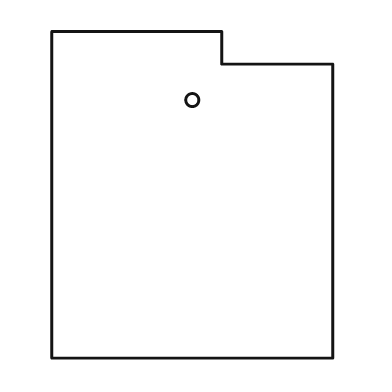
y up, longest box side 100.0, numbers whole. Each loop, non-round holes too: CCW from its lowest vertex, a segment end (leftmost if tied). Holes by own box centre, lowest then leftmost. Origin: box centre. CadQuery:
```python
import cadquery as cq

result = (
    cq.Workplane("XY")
    .moveTo(-43.0, -50.0)
    .lineTo(43.0, -50.0)
    .lineTo(43.0, 40.0)
    .lineTo(9.0, 40.0)
    .lineTo(9.0, 50.0)
    .lineTo(-43.0, 50.0)
    .close()
    .moveTo(0.0, 29.0)
    .circle(2.0)
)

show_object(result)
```